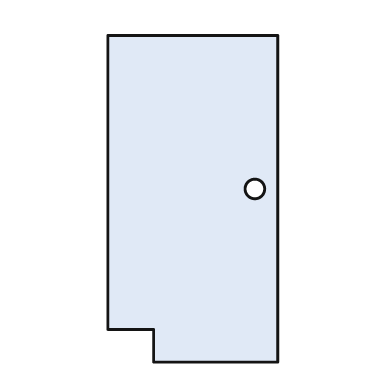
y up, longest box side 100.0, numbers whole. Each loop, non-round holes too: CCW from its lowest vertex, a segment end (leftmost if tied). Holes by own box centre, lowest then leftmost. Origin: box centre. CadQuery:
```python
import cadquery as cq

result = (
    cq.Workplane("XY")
    .moveTo(-12.0, -50.0)
    .lineTo(26.0, -50.0)
    .lineTo(26.0, 50.0)
    .lineTo(-26.0, 50.0)
    .lineTo(-26.0, -40.0)
    .lineTo(-12.0, -40.0)
    .close()
    .moveTo(19.0, 3.0)
    .circle(3.0)
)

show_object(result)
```